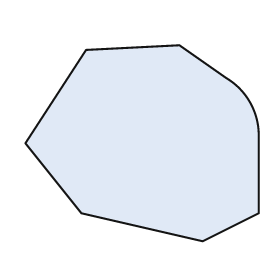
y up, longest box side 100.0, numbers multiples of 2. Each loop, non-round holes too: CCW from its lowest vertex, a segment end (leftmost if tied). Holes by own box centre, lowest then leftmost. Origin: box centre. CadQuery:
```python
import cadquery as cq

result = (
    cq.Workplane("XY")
    .moveTo(26.0, -42.0)
    .lineTo(50.0, -30.0)
    .lineTo(50.0, 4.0)
    .threePointArc((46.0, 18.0), (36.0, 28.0))
    .lineTo(16.0, 42.0)
    .lineTo(-24.0, 40.0)
    .lineTo(-50.0, 0.0)
    .lineTo(-26.0, -30.0)
    .close()
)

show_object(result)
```